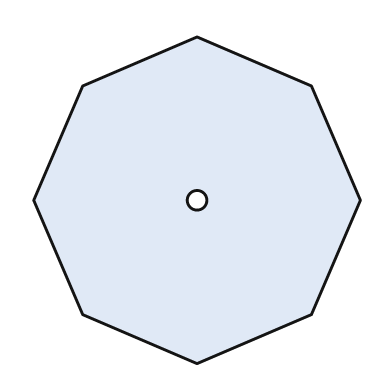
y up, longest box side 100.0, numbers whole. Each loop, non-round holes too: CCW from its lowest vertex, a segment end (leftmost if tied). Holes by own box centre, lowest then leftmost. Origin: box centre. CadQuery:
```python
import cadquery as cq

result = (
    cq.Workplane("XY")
    .moveTo(0.0, -50.0)
    .lineTo(35.0, -35.0)
    .lineTo(50.0, 0.0)
    .lineTo(35.0, 35.0)
    .lineTo(0.0, 50.0)
    .lineTo(-35.0, 35.0)
    .lineTo(-50.0, 0.0)
    .lineTo(-35.0, -35.0)
    .close()
    .moveTo(0.0, 0.0)
    .circle(3.0)
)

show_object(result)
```